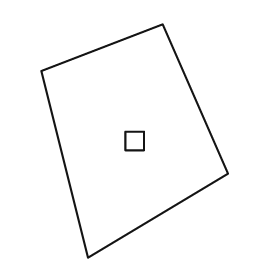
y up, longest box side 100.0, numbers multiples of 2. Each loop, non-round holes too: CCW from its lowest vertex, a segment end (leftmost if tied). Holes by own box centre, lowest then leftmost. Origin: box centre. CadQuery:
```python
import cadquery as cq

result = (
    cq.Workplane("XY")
    .moveTo(-20.0, -50.0)
    .lineTo(40.0, -14.0)
    .lineTo(12.0, 50.0)
    .lineTo(-40.0, 30.0)
    .close()
    .moveTo(-4.0, -4.0)
    .lineTo(4.0, -4.0)
    .lineTo(4.0, 4.0)
    .lineTo(-4.0, 4.0)
    .close()
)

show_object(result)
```